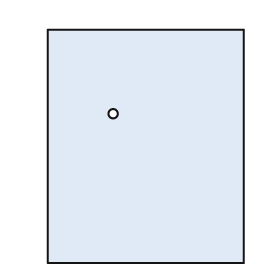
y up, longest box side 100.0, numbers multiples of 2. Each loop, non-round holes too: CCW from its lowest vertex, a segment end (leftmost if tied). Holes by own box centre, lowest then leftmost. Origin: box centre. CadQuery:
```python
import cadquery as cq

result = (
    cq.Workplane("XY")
    .moveTo(-42.0, -50.0)
    .lineTo(42.0, -50.0)
    .lineTo(42.0, 50.0)
    .lineTo(-42.0, 50.0)
    .close()
    .moveTo(-14.0, 14.0)
    .circle(2.0)
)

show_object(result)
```